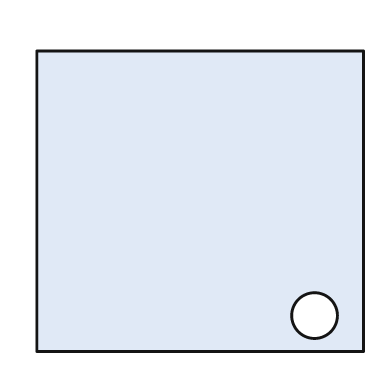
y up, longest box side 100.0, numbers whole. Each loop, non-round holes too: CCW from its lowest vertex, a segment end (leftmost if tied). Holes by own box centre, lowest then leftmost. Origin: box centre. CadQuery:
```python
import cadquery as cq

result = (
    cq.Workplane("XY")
    .moveTo(-50.0, -46.0)
    .lineTo(50.0, -46.0)
    .lineTo(50.0, 46.0)
    .lineTo(-50.0, 46.0)
    .close()
    .moveTo(35.0, -35.0)
    .circle(7.0)
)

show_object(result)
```